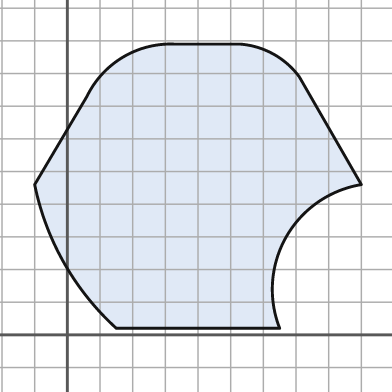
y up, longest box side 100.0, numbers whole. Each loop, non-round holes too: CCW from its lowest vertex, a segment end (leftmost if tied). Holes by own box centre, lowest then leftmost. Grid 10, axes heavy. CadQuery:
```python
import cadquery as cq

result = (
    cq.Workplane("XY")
    .moveTo(15.0, 2.0)
    .lineTo(65.0, 2.0)
    .threePointArc((67.0, 30.0), (90.0, 46.0))
    .lineTo(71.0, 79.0)
    .threePointArc((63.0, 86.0), (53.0, 89.0))
    .lineTo(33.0, 89.0)
    .threePointArc((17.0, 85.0), (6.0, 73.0))
    .lineTo(-10.0, 46.0)
    .threePointArc((-1.0, 22.0), (15.0, 2.0))
    .close()
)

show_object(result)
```